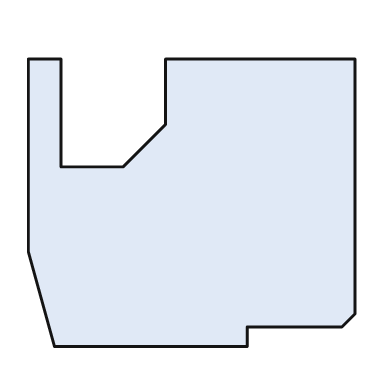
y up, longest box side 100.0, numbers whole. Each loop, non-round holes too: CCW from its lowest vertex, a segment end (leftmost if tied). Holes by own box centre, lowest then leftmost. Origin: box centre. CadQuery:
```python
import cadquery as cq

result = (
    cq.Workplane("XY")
    .moveTo(-42.0, -44.0)
    .lineTo(17.0, -44.0)
    .lineTo(17.0, -38.0)
    .lineTo(46.0, -38.0)
    .lineTo(50.0, -34.0)
    .lineTo(50.0, 44.0)
    .lineTo(-8.0, 44.0)
    .lineTo(-8.0, 24.0)
    .lineTo(-21.0, 11.0)
    .lineTo(-40.0, 11.0)
    .lineTo(-40.0, 44.0)
    .lineTo(-50.0, 44.0)
    .lineTo(-50.0, -15.0)
    .close()
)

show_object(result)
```